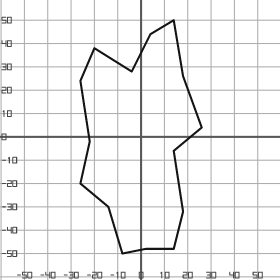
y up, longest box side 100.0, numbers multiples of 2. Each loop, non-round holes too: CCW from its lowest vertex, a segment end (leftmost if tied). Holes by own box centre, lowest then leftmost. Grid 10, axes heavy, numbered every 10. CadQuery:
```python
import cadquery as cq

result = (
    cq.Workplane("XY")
    .moveTo(-8.0, -50.0)
    .lineTo(2.0, -48.0)
    .lineTo(14.0, -48.0)
    .lineTo(18.0, -32.0)
    .lineTo(14.0, -6.0)
    .lineTo(26.0, 4.0)
    .lineTo(18.0, 26.0)
    .lineTo(14.0, 50.0)
    .lineTo(4.0, 44.0)
    .lineTo(-4.0, 28.0)
    .lineTo(-20.0, 38.0)
    .lineTo(-26.0, 24.0)
    .lineTo(-22.0, -2.0)
    .lineTo(-26.0, -20.0)
    .lineTo(-14.0, -30.0)
    .close()
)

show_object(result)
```